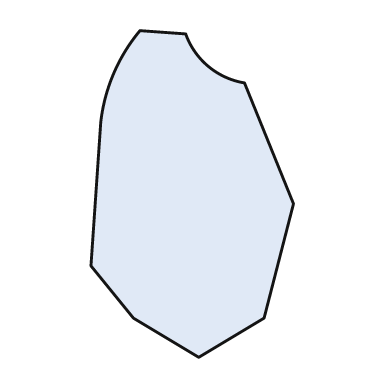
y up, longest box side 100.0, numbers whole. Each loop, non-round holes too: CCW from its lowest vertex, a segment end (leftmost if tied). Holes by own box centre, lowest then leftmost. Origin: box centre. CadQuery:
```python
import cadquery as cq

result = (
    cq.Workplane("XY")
    .moveTo(2.0, -50.0)
    .lineTo(22.0, -38.0)
    .lineTo(31.0, -3.0)
    .lineTo(16.0, 34.0)
    .threePointArc((5.0, 39.0), (-2.0, 49.0))
    .lineTo(-16.0, 50.0)
    .threePointArc((-24.0, 37.0), (-28.0, 22.0))
    .lineTo(-31.0, -22.0)
    .lineTo(-18.0, -38.0)
    .close()
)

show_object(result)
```